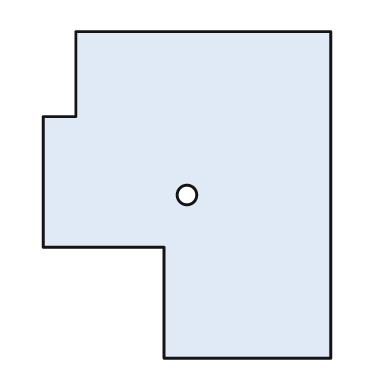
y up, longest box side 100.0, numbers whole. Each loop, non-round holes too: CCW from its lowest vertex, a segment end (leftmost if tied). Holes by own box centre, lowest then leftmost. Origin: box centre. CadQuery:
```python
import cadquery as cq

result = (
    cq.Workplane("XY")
    .moveTo(-7.0, -50.0)
    .lineTo(44.0, -50.0)
    .lineTo(44.0, 50.0)
    .lineTo(-34.0, 50.0)
    .lineTo(-34.0, 24.0)
    .lineTo(-44.0, 24.0)
    .lineTo(-44.0, -16.0)
    .lineTo(-7.0, -16.0)
    .close()
    .moveTo(0.0, 0.0)
    .circle(3.0)
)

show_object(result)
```